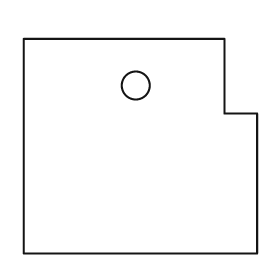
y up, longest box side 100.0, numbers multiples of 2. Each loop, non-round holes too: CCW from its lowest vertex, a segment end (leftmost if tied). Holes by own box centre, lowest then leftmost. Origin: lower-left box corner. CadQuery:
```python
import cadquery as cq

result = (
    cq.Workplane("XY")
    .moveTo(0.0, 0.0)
    .lineTo(100.0, 0.0)
    .lineTo(100.0, 60.0)
    .lineTo(86.0, 60.0)
    .lineTo(86.0, 92.0)
    .lineTo(0.0, 92.0)
    .close()
    .moveTo(48.0, 72.0)
    .circle(6.0)
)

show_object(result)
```